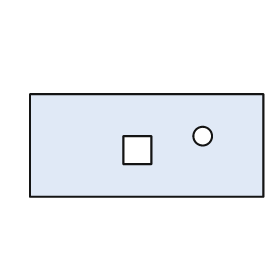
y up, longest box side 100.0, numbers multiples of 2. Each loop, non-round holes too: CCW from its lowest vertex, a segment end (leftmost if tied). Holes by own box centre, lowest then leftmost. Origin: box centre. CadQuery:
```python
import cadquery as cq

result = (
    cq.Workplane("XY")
    .moveTo(-50.0, -22.0)
    .lineTo(50.0, -22.0)
    .lineTo(50.0, 22.0)
    .lineTo(-50.0, 22.0)
    .close()
    .moveTo(-10.0, -8.0)
    .lineTo(2.0, -8.0)
    .lineTo(2.0, 4.0)
    .lineTo(-10.0, 4.0)
    .close()
    .moveTo(24.0, 4.0)
    .circle(4.0)
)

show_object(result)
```